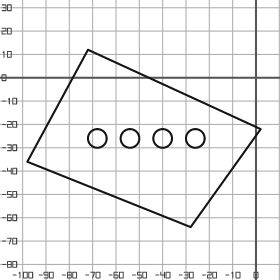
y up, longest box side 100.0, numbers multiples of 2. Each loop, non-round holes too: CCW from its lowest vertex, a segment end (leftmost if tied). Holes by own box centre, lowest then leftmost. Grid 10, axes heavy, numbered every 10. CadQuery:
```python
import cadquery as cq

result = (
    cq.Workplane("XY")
    .moveTo(-28.0, -64.0)
    .lineTo(2.0, -22.0)
    .lineTo(-72.0, 12.0)
    .lineTo(-98.0, -36.0)
    .close()
    .moveTo(-68.0, -26.0)
    .circle(4.0)
    .moveTo(-54.0, -26.0)
    .circle(4.0)
    .moveTo(-40.0, -26.0)
    .circle(4.0)
    .moveTo(-26.0, -26.0)
    .circle(4.0)
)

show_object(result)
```